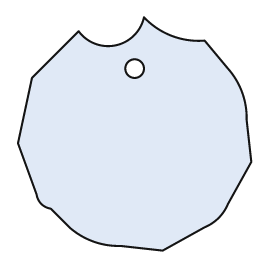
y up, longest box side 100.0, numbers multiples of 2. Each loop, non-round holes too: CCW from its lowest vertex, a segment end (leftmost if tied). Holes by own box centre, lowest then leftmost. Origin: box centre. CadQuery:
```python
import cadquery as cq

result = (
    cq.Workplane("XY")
    .moveTo(12.0, -50.0)
    .lineTo(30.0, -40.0)
    .threePointArc((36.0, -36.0), (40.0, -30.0))
    .lineTo(50.0, -12.0)
    .lineTo(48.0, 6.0)
    .threePointArc((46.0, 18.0), (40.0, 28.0))
    .lineTo(30.0, 40.0)
    .threePointArc((16.0, 42.0), (4.0, 50.0))
    .threePointArc((-8.0, 38.0), (-24.0, 44.0))
    .lineTo(-44.0, 24.0)
    .lineTo(-50.0, -4.0)
    .lineTo(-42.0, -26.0)
    .threePointArc((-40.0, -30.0), (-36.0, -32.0))
    .lineTo(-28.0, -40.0)
    .threePointArc((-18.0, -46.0), (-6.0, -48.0))
    .close()
    .moveTo(0.0, 28.0)
    .circle(4.0)
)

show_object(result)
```